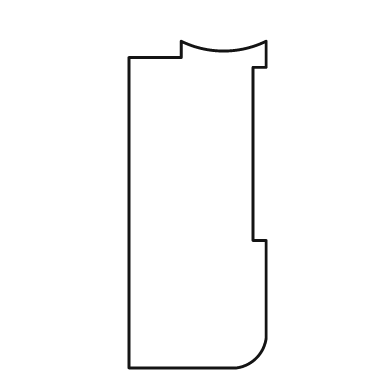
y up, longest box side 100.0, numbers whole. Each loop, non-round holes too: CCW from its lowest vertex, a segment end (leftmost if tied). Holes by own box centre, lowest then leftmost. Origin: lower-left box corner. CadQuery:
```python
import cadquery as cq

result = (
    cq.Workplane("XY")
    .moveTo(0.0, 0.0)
    .lineTo(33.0, 0.0)
    .threePointArc((39.0, 3.0), (42.0, 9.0))
    .lineTo(42.0, 39.0)
    .lineTo(38.0, 39.0)
    .lineTo(38.0, 92.0)
    .lineTo(42.0, 92.0)
    .lineTo(42.0, 100.0)
    .threePointArc((29.0, 97.0), (16.0, 100.0))
    .lineTo(16.0, 95.0)
    .lineTo(0.0, 95.0)
    .close()
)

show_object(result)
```